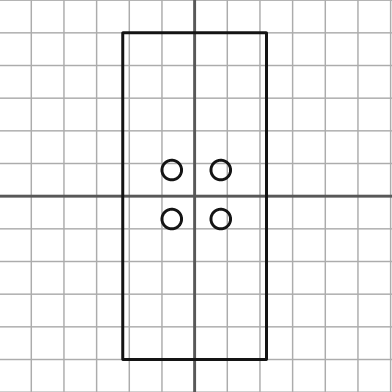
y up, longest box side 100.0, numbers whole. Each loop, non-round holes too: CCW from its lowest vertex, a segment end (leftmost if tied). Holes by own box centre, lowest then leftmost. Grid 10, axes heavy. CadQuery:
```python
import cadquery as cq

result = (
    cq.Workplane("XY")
    .moveTo(-22.0, -50.0)
    .lineTo(22.0, -50.0)
    .lineTo(22.0, 50.0)
    .lineTo(-22.0, 50.0)
    .close()
    .moveTo(-7.0, -7.0)
    .circle(3.0)
    .moveTo(8.0, -7.0)
    .circle(3.0)
    .moveTo(-7.0, 8.0)
    .circle(3.0)
    .moveTo(8.0, 8.0)
    .circle(3.0)
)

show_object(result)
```